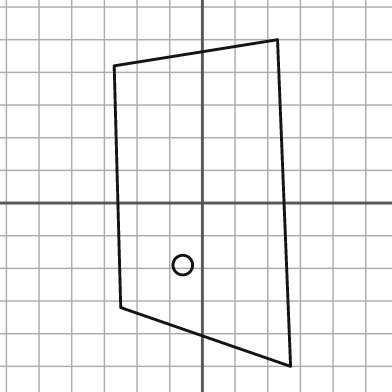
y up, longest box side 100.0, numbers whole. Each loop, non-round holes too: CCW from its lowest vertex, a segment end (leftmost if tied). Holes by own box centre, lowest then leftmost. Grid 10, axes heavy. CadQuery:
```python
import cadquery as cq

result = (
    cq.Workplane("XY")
    .moveTo(27.0, -50.0)
    .lineTo(23.0, 50.0)
    .lineTo(-27.0, 42.0)
    .lineTo(-25.0, -32.0)
    .close()
    .moveTo(-6.0, -19.0)
    .circle(3.0)
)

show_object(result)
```